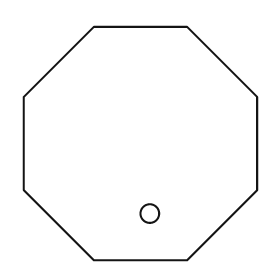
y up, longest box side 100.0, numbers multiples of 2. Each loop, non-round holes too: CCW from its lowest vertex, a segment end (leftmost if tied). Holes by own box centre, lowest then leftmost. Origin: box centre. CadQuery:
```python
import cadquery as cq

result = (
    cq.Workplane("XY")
    .moveTo(-20.0, -50.0)
    .lineTo(20.0, -50.0)
    .lineTo(50.0, -20.0)
    .lineTo(50.0, 20.0)
    .lineTo(20.0, 50.0)
    .lineTo(-20.0, 50.0)
    .lineTo(-50.0, 20.0)
    .lineTo(-50.0, -20.0)
    .close()
    .moveTo(4.0, -30.0)
    .circle(4.0)
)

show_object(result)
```